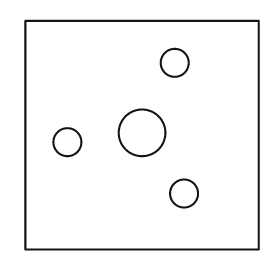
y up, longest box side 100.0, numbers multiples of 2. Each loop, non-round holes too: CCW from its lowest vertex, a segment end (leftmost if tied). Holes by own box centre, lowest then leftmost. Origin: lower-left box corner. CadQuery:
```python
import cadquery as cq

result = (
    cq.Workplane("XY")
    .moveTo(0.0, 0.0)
    .lineTo(100.0, 0.0)
    .lineTo(100.0, 98.0)
    .lineTo(0.0, 98.0)
    .close()
    .moveTo(68.0, 24.0)
    .circle(6.0)
    .moveTo(18.0, 46.0)
    .circle(6.0)
    .moveTo(50.0, 50.0)
    .circle(10.0)
    .moveTo(64.0, 80.0)
    .circle(6.0)
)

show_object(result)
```